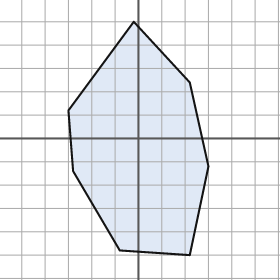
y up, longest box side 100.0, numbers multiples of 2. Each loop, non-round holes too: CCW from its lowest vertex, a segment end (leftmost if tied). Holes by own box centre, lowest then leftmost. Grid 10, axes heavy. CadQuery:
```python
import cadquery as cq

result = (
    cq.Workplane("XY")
    .moveTo(22.0, -50.0)
    .lineTo(30.0, -12.0)
    .lineTo(22.0, 24.0)
    .lineTo(-2.0, 50.0)
    .lineTo(-30.0, 12.0)
    .lineTo(-28.0, -14.0)
    .lineTo(-8.0, -48.0)
    .close()
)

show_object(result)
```